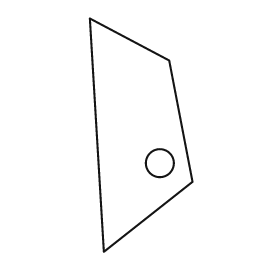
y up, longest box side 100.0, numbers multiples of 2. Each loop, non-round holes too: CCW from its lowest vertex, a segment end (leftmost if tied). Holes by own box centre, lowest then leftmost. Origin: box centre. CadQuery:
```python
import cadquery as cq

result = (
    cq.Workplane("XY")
    .moveTo(-16.0, -50.0)
    .lineTo(22.0, -20.0)
    .lineTo(12.0, 32.0)
    .lineTo(-22.0, 50.0)
    .close()
    .moveTo(8.0, -12.0)
    .circle(6.0)
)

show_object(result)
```